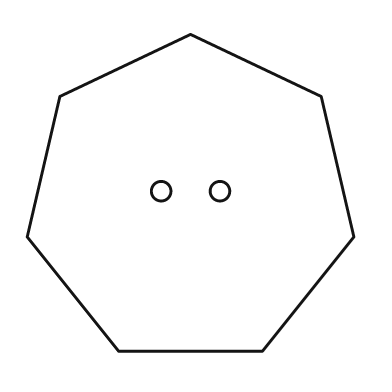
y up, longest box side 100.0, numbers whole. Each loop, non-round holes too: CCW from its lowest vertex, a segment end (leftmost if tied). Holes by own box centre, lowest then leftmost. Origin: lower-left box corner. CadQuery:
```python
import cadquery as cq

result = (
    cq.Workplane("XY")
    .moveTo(28.0, 0.0)
    .lineTo(72.0, 0.0)
    .lineTo(100.0, 35.0)
    .lineTo(90.0, 78.0)
    .lineTo(50.0, 97.0)
    .lineTo(10.0, 78.0)
    .lineTo(0.0, 35.0)
    .close()
    .moveTo(41.0, 49.0)
    .circle(3.0)
    .moveTo(59.0, 49.0)
    .circle(3.0)
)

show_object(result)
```